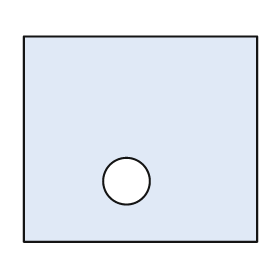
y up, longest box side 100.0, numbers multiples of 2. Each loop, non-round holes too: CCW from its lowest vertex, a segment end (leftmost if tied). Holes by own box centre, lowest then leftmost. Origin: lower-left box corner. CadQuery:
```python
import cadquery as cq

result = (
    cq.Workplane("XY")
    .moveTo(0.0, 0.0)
    .lineTo(100.0, 0.0)
    .lineTo(100.0, 88.0)
    .lineTo(0.0, 88.0)
    .close()
    .moveTo(44.0, 26.0)
    .circle(10.0)
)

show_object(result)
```